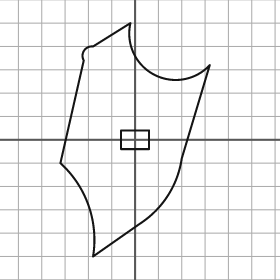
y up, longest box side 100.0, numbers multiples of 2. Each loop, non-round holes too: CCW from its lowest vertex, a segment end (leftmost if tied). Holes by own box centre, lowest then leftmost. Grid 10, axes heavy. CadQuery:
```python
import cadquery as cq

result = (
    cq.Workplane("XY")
    .moveTo(-18.0, -50.0)
    .lineTo(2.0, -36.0)
    .threePointArc((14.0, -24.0), (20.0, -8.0))
    .lineTo(32.0, 32.0)
    .threePointArc((8.0, 28.0), (-2.0, 50.0))
    .lineTo(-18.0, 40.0)
    .threePointArc((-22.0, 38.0), (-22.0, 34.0))
    .lineTo(-32.0, -10.0)
    .threePointArc((-20.0, -28.0), (-18.0, -50.0))
    .close()
    .moveTo(-6.0, -4.0)
    .lineTo(6.0, -4.0)
    .lineTo(6.0, 4.0)
    .lineTo(-6.0, 4.0)
    .close()
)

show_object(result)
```